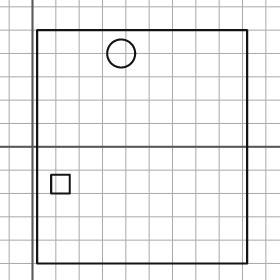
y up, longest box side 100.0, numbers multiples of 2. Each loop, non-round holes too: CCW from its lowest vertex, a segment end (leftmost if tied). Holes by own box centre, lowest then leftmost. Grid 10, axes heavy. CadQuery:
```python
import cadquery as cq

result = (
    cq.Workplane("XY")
    .moveTo(2.0, -50.0)
    .lineTo(92.0, -50.0)
    .lineTo(92.0, 50.0)
    .lineTo(2.0, 50.0)
    .close()
    .moveTo(8.0, -20.0)
    .lineTo(16.0, -20.0)
    .lineTo(16.0, -12.0)
    .lineTo(8.0, -12.0)
    .close()
    .moveTo(38.0, 40.0)
    .circle(6.0)
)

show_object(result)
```